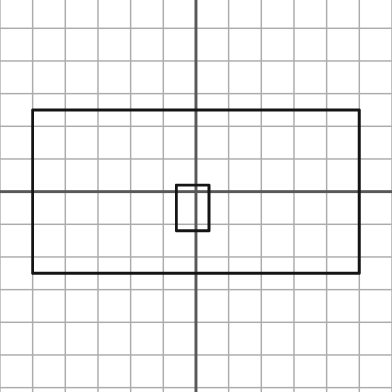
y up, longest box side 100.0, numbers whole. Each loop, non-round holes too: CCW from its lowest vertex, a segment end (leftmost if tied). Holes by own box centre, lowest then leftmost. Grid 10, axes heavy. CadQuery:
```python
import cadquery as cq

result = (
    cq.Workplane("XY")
    .moveTo(-50.0, -25.0)
    .lineTo(50.0, -25.0)
    .lineTo(50.0, 25.0)
    .lineTo(-50.0, 25.0)
    .close()
    .moveTo(-6.0, -12.0)
    .lineTo(4.0, -12.0)
    .lineTo(4.0, 2.0)
    .lineTo(-6.0, 2.0)
    .close()
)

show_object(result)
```